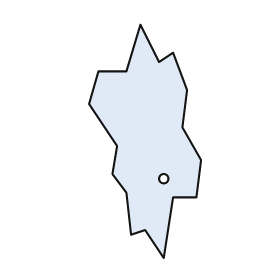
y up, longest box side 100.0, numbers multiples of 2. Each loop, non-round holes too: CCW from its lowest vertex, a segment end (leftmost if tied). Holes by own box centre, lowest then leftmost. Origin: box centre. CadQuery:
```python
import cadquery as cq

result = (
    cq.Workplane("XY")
    .moveTo(8.0, -50.0)
    .lineTo(12.0, -24.0)
    .lineTo(22.0, -24.0)
    .lineTo(24.0, -8.0)
    .lineTo(16.0, 6.0)
    .lineTo(18.0, 22.0)
    .lineTo(12.0, 38.0)
    .lineTo(6.0, 34.0)
    .lineTo(-2.0, 50.0)
    .lineTo(-8.0, 30.0)
    .lineTo(-20.0, 30.0)
    .lineTo(-24.0, 16.0)
    .lineTo(-12.0, -2.0)
    .lineTo(-14.0, -14.0)
    .lineTo(-8.0, -22.0)
    .lineTo(-6.0, -40.0)
    .lineTo(0.0, -38.0)
    .close()
    .moveTo(8.0, -16.0)
    .circle(2.0)
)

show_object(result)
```